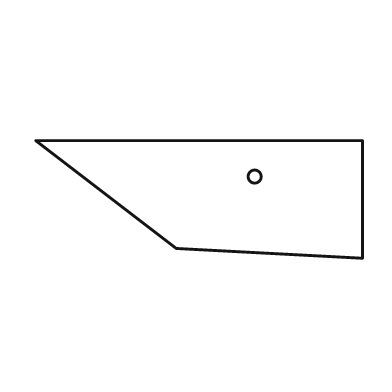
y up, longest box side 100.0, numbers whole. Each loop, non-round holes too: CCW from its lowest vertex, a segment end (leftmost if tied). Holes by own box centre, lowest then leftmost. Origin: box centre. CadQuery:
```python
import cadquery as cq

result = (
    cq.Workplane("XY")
    .moveTo(50.0, -18.0)
    .lineTo(50.0, 18.0)
    .lineTo(-50.0, 18.0)
    .lineTo(-7.0, -15.0)
    .close()
    .moveTo(17.0, 7.0)
    .circle(2.0)
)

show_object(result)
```